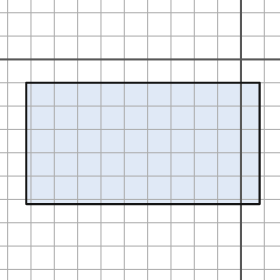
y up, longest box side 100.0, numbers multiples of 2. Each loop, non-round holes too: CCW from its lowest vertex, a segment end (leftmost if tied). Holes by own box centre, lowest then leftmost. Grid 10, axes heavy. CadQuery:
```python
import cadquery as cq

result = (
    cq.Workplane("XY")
    .moveTo(-92.0, -62.0)
    .lineTo(8.0, -62.0)
    .lineTo(8.0, -10.0)
    .lineTo(-92.0, -10.0)
    .close()
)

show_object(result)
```